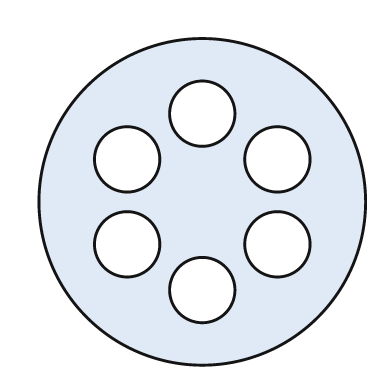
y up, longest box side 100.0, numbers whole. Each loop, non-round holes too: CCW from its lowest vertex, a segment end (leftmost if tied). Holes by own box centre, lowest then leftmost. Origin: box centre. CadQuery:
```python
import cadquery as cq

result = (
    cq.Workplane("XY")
    .moveTo(0.0, 0.0)
    .circle(50.0)
    .moveTo(0.0, -27.0)
    .circle(10.0)
    .moveTo(-23.0, -13.0)
    .circle(10.0)
    .moveTo(23.0, -13.0)
    .circle(10.0)
    .moveTo(-23.0, 13.0)
    .circle(10.0)
    .moveTo(23.0, 13.0)
    .circle(10.0)
    .moveTo(0.0, 27.0)
    .circle(10.0)
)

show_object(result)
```